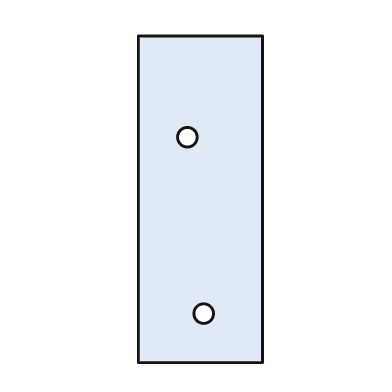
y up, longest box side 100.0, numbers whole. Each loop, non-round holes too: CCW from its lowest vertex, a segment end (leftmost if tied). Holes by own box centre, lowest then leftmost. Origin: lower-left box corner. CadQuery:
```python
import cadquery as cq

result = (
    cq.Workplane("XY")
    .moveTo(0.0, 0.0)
    .lineTo(38.0, 0.0)
    .lineTo(38.0, 100.0)
    .lineTo(0.0, 100.0)
    .close()
    .moveTo(20.0, 15.0)
    .circle(3.0)
    .moveTo(15.0, 69.0)
    .circle(3.0)
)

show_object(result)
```